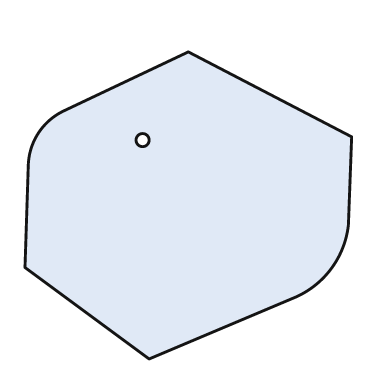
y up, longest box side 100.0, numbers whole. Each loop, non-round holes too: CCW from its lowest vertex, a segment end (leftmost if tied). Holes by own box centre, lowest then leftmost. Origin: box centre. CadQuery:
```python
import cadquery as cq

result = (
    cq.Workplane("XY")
    .moveTo(-12.0, -47.0)
    .lineTo(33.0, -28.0)
    .threePointArc((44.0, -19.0), (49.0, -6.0))
    .lineTo(50.0, 21.0)
    .lineTo(0.0, 47.0)
    .lineTo(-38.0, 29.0)
    .threePointArc((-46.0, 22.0), (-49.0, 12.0))
    .lineTo(-50.0, -19.0)
    .close()
    .moveTo(-14.0, 20.0)
    .circle(2.0)
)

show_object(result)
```